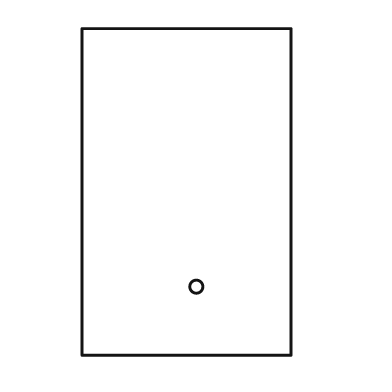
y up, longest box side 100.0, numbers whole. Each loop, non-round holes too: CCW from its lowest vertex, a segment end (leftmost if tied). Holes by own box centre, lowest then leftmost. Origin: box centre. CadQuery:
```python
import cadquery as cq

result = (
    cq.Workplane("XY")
    .moveTo(-32.0, -50.0)
    .lineTo(32.0, -50.0)
    .lineTo(32.0, 50.0)
    .lineTo(-32.0, 50.0)
    .close()
    .moveTo(3.0, -29.0)
    .circle(2.0)
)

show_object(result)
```